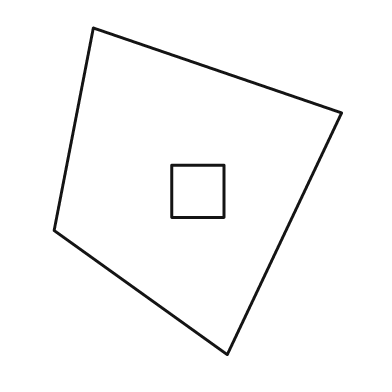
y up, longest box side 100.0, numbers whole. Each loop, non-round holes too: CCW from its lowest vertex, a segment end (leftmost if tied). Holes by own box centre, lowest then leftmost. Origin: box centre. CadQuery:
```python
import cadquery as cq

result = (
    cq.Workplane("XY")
    .moveTo(9.0, -50.0)
    .lineTo(44.0, 24.0)
    .lineTo(-32.0, 50.0)
    .lineTo(-44.0, -12.0)
    .close()
    .moveTo(-8.0, -8.0)
    .lineTo(8.0, -8.0)
    .lineTo(8.0, 8.0)
    .lineTo(-8.0, 8.0)
    .close()
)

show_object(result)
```